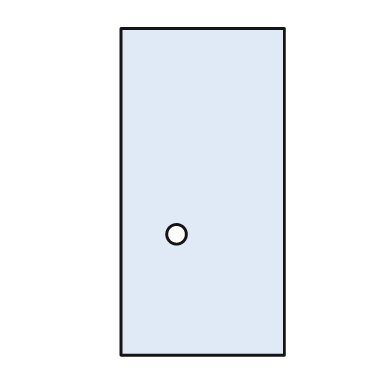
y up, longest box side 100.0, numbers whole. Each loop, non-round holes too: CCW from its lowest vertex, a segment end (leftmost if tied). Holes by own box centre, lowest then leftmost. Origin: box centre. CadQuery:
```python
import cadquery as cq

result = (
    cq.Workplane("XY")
    .moveTo(-25.0, -50.0)
    .lineTo(25.0, -50.0)
    .lineTo(25.0, 50.0)
    .lineTo(-25.0, 50.0)
    .close()
    .moveTo(-8.0, -13.0)
    .circle(3.0)
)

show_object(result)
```